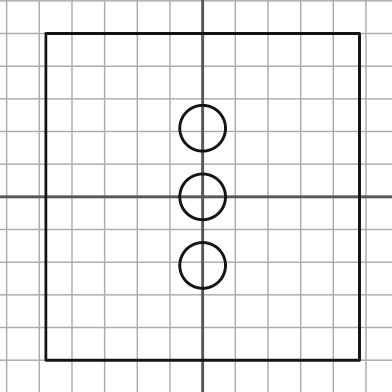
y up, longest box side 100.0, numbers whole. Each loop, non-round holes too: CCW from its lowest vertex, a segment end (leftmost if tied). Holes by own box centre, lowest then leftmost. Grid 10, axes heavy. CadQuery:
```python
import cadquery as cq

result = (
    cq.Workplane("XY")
    .moveTo(-48.0, -50.0)
    .lineTo(48.0, -50.0)
    .lineTo(48.0, 50.0)
    .lineTo(-48.0, 50.0)
    .close()
    .moveTo(0.0, -21.0)
    .circle(7.0)
    .moveTo(0.0, 0.0)
    .circle(7.0)
    .moveTo(0.0, 21.0)
    .circle(7.0)
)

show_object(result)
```